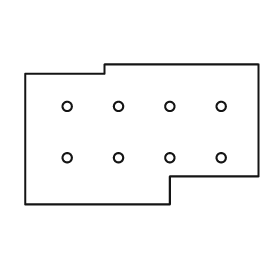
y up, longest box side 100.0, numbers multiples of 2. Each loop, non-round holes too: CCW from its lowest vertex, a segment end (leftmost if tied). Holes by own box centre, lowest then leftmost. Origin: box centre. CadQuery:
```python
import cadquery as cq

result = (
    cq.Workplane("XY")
    .moveTo(-50.0, -30.0)
    .lineTo(12.0, -30.0)
    .lineTo(12.0, -18.0)
    .lineTo(50.0, -18.0)
    .lineTo(50.0, 30.0)
    .lineTo(-16.0, 30.0)
    .lineTo(-16.0, 26.0)
    .lineTo(-50.0, 26.0)
    .close()
    .moveTo(-32.0, -10.0)
    .circle(2.0)
    .moveTo(-10.0, -10.0)
    .circle(2.0)
    .moveTo(12.0, -10.0)
    .circle(2.0)
    .moveTo(34.0, -10.0)
    .circle(2.0)
    .moveTo(-32.0, 12.0)
    .circle(2.0)
    .moveTo(-10.0, 12.0)
    .circle(2.0)
    .moveTo(12.0, 12.0)
    .circle(2.0)
    .moveTo(34.0, 12.0)
    .circle(2.0)
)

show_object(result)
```